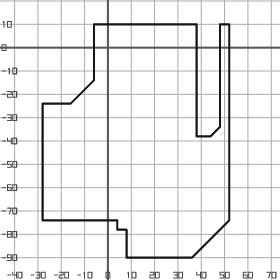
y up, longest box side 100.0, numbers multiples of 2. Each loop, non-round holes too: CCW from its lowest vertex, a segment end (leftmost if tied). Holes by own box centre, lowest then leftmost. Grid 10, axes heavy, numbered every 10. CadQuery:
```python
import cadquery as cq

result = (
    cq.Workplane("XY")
    .moveTo(8.0, -90.0)
    .lineTo(36.0, -90.0)
    .lineTo(52.0, -74.0)
    .lineTo(52.0, 10.0)
    .lineTo(48.0, 10.0)
    .lineTo(48.0, -34.0)
    .lineTo(44.0, -38.0)
    .lineTo(38.0, -38.0)
    .lineTo(38.0, 10.0)
    .lineTo(-6.0, 10.0)
    .lineTo(-6.0, -14.0)
    .lineTo(-16.0, -24.0)
    .lineTo(-28.0, -24.0)
    .lineTo(-28.0, -74.0)
    .lineTo(4.0, -74.0)
    .lineTo(4.0, -78.0)
    .lineTo(8.0, -78.0)
    .close()
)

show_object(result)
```